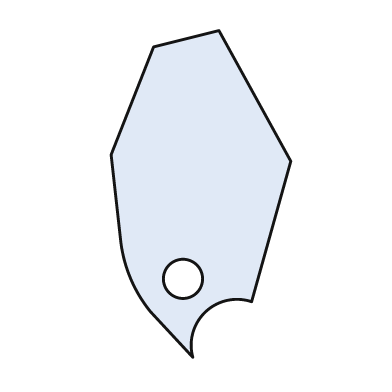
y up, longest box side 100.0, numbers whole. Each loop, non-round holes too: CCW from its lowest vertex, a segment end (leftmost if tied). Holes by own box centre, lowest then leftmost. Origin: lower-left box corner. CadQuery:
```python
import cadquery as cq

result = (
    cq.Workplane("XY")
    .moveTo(25.0, 0.0)
    .threePointArc((29.0, 14.0), (43.0, 17.0))
    .lineTo(55.0, 60.0)
    .lineTo(33.0, 100.0)
    .lineTo(13.0, 95.0)
    .lineTo(0.0, 62.0)
    .lineTo(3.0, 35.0)
    .threePointArc((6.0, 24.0), (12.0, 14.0))
    .close()
    .moveTo(22.0, 24.0)
    .circle(6.0)
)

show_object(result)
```